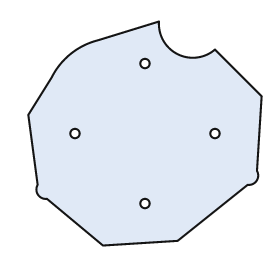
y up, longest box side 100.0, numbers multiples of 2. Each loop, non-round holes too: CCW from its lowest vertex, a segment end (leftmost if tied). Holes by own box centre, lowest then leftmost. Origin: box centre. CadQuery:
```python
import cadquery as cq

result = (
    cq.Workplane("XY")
    .moveTo(-18.0, -48.0)
    .lineTo(14.0, -46.0)
    .lineTo(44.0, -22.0)
    .threePointArc((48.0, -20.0), (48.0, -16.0))
    .lineTo(50.0, 16.0)
    .lineTo(30.0, 36.0)
    .threePointArc((14.0, 34.0), (6.0, 48.0))
    .lineTo(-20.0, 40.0)
    .threePointArc((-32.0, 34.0), (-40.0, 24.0))
    .lineTo(-50.0, 8.0)
    .lineTo(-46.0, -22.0)
    .threePointArc((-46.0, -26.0), (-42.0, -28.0))
    .close()
    .moveTo(0.0, -30.0)
    .circle(2.0)
    .moveTo(-30.0, 0.0)
    .circle(2.0)
    .moveTo(30.0, 0.0)
    .circle(2.0)
    .moveTo(0.0, 30.0)
    .circle(2.0)
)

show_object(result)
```